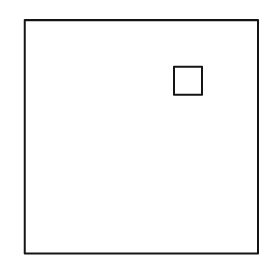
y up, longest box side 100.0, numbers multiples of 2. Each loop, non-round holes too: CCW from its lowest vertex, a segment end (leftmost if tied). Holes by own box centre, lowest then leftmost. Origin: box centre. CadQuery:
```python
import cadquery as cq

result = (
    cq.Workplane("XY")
    .moveTo(-50.0, -50.0)
    .lineTo(50.0, -50.0)
    .lineTo(50.0, 50.0)
    .lineTo(-50.0, 50.0)
    .close()
    .moveTo(14.0, 18.0)
    .lineTo(26.0, 18.0)
    .lineTo(26.0, 30.0)
    .lineTo(14.0, 30.0)
    .close()
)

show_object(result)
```